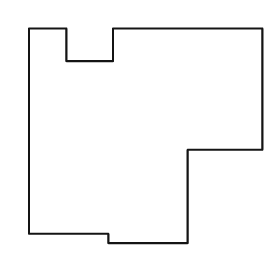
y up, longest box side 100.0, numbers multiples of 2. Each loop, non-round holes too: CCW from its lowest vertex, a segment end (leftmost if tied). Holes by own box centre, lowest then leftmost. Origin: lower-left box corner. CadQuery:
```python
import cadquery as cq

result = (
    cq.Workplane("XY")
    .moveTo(34.0, 0.0)
    .lineTo(68.0, 0.0)
    .lineTo(68.0, 40.0)
    .lineTo(100.0, 40.0)
    .lineTo(100.0, 92.0)
    .lineTo(36.0, 92.0)
    .lineTo(36.0, 78.0)
    .lineTo(16.0, 78.0)
    .lineTo(16.0, 92.0)
    .lineTo(0.0, 92.0)
    .lineTo(0.0, 4.0)
    .lineTo(34.0, 4.0)
    .close()
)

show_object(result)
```